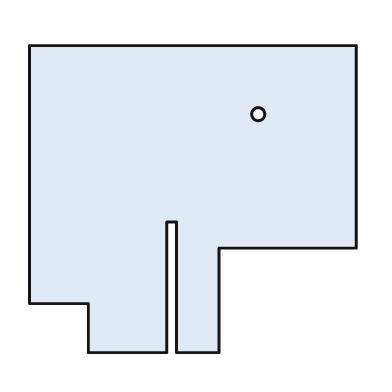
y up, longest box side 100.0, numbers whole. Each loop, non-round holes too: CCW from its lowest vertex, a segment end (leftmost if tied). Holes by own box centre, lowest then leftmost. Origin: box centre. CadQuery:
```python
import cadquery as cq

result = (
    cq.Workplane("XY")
    .moveTo(-32.0, -47.0)
    .lineTo(-8.0, -47.0)
    .lineTo(-8.0, -7.0)
    .lineTo(-5.0, -7.0)
    .lineTo(-5.0, -47.0)
    .lineTo(8.0, -47.0)
    .lineTo(8.0, -15.0)
    .lineTo(50.0, -15.0)
    .lineTo(50.0, 47.0)
    .lineTo(-50.0, 47.0)
    .lineTo(-50.0, -32.0)
    .lineTo(-32.0, -32.0)
    .close()
    .moveTo(20.0, 26.0)
    .circle(2.0)
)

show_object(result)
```